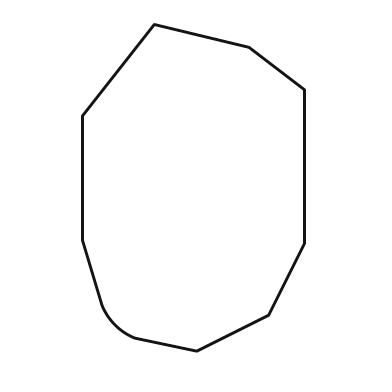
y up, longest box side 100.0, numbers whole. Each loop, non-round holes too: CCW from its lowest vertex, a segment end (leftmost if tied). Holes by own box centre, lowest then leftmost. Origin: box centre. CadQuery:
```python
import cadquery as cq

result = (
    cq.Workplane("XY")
    .moveTo(1.0, -50.0)
    .lineTo(23.0, -39.0)
    .lineTo(34.0, -17.0)
    .lineTo(34.0, 30.0)
    .lineTo(17.0, 43.0)
    .lineTo(-12.0, 50.0)
    .lineTo(-34.0, 22.0)
    .lineTo(-34.0, -16.0)
    .lineTo(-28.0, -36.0)
    .threePointArc((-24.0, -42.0), (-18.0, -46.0))
    .close()
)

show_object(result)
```